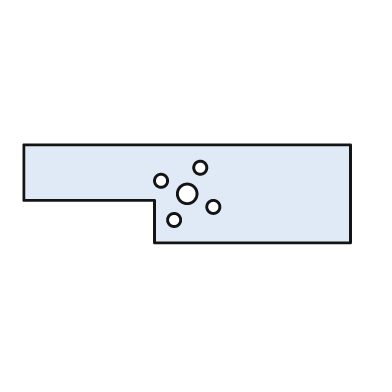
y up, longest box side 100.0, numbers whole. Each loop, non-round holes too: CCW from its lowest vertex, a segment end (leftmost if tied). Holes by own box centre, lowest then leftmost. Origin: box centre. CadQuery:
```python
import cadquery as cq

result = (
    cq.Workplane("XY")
    .moveTo(-10.0, -15.0)
    .lineTo(50.0, -15.0)
    .lineTo(50.0, 15.0)
    .lineTo(-50.0, 15.0)
    .lineTo(-50.0, -2.0)
    .lineTo(-10.0, -2.0)
    .close()
    .moveTo(-4.0, -8.0)
    .circle(2.0)
    .moveTo(8.0, -4.0)
    .circle(2.0)
    .moveTo(0.0, 0.0)
    .circle(3.0)
    .moveTo(-8.0, 4.0)
    .circle(2.0)
    .moveTo(4.0, 8.0)
    .circle(2.0)
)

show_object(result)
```